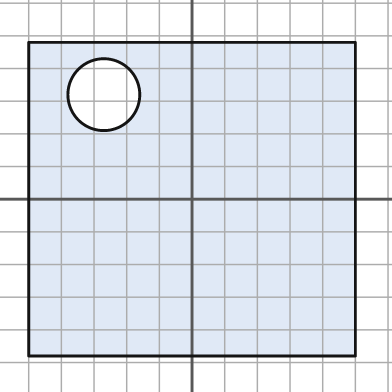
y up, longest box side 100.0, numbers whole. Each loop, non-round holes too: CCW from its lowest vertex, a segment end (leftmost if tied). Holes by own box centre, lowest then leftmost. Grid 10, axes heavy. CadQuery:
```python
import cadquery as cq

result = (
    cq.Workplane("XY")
    .moveTo(-50.0, -48.0)
    .lineTo(50.0, -48.0)
    .lineTo(50.0, 48.0)
    .lineTo(-50.0, 48.0)
    .close()
    .moveTo(-27.0, 32.0)
    .circle(11.0)
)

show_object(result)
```